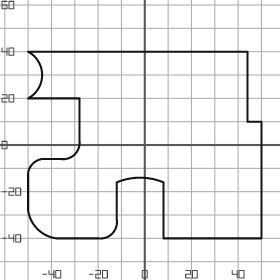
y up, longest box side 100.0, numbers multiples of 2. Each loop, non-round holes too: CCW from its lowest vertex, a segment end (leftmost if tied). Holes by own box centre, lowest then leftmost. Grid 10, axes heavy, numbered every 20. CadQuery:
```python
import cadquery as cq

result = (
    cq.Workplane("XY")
    .moveTo(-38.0, -40.0)
    .lineTo(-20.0, -40.0)
    .threePointArc((-14.0, -38.0), (-12.0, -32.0))
    .lineTo(-12.0, -16.0)
    .threePointArc((-2.0, -14.0), (8.0, -16.0))
    .lineTo(8.0, -40.0)
    .lineTo(50.0, -40.0)
    .lineTo(50.0, 10.0)
    .lineTo(44.0, 10.0)
    .lineTo(44.0, 40.0)
    .lineTo(-50.0, 40.0)
    .threePointArc((-44.0, 30.0), (-50.0, 20.0))
    .lineTo(-28.0, 20.0)
    .lineTo(-28.0, 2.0)
    .threePointArc((-30.0, -4.0), (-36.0, -6.0))
    .lineTo(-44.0, -6.0)
    .threePointArc((-48.0, -8.0), (-50.0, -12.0))
    .lineTo(-50.0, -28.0)
    .threePointArc((-46.0, -36.0), (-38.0, -40.0))
    .close()
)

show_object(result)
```